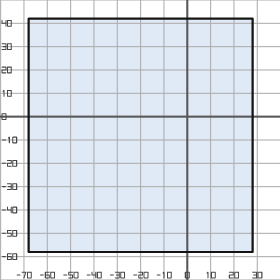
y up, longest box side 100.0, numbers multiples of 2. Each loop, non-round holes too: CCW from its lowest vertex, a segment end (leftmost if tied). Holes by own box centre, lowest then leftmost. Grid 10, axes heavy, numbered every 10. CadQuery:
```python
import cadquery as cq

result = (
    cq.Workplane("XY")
    .moveTo(-68.0, -58.0)
    .lineTo(28.0, -58.0)
    .lineTo(28.0, 42.0)
    .lineTo(-68.0, 42.0)
    .close()
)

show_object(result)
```